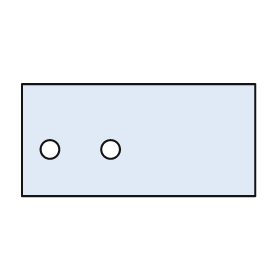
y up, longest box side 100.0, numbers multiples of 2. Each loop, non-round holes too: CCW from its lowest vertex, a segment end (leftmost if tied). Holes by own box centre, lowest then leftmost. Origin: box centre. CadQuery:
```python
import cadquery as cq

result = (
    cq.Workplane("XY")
    .moveTo(-50.0, -24.0)
    .lineTo(50.0, -24.0)
    .lineTo(50.0, 24.0)
    .lineTo(-50.0, 24.0)
    .close()
    .moveTo(-38.0, -4.0)
    .circle(4.0)
    .moveTo(-12.0, -4.0)
    .circle(4.0)
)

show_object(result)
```